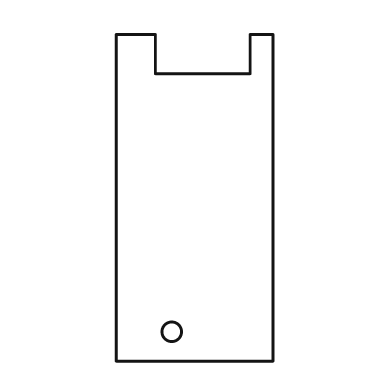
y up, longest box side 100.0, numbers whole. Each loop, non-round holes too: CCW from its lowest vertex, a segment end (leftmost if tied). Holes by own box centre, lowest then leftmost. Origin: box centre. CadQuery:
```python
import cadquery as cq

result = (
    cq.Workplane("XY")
    .moveTo(-24.0, -50.0)
    .lineTo(24.0, -50.0)
    .lineTo(24.0, 50.0)
    .lineTo(17.0, 50.0)
    .lineTo(17.0, 38.0)
    .lineTo(-12.0, 38.0)
    .lineTo(-12.0, 50.0)
    .lineTo(-24.0, 50.0)
    .close()
    .moveTo(-7.0, -41.0)
    .circle(3.0)
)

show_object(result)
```